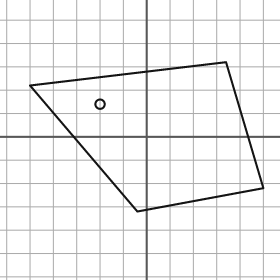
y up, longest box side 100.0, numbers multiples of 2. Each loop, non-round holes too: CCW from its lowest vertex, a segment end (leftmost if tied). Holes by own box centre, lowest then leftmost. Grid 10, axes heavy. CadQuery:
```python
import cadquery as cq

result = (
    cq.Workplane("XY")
    .moveTo(-4.0, -32.0)
    .lineTo(50.0, -22.0)
    .lineTo(34.0, 32.0)
    .lineTo(-50.0, 22.0)
    .close()
    .moveTo(-20.0, 14.0)
    .circle(2.0)
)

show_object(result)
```